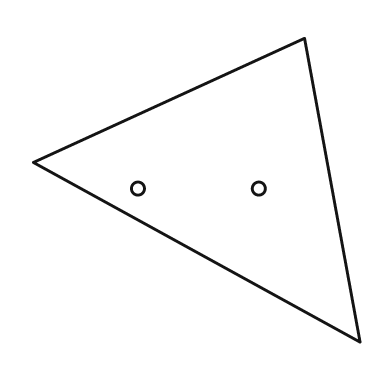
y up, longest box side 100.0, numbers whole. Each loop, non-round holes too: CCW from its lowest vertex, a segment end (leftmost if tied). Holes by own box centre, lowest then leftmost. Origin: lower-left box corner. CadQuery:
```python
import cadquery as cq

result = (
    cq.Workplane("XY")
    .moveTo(100.0, 0.0)
    .lineTo(83.0, 93.0)
    .lineTo(0.0, 55.0)
    .close()
    .moveTo(32.0, 47.0)
    .circle(2.0)
    .moveTo(69.0, 47.0)
    .circle(2.0)
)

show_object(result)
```